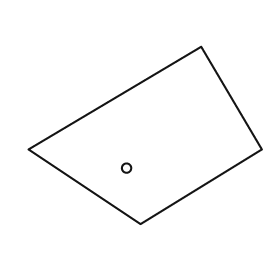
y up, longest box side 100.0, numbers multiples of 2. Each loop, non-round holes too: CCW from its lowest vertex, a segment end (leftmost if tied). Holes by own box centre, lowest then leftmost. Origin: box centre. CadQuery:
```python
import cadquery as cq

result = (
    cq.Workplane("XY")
    .moveTo(-2.0, -38.0)
    .lineTo(50.0, -6.0)
    .lineTo(24.0, 38.0)
    .lineTo(-50.0, -6.0)
    .close()
    .moveTo(-8.0, -14.0)
    .circle(2.0)
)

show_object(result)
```